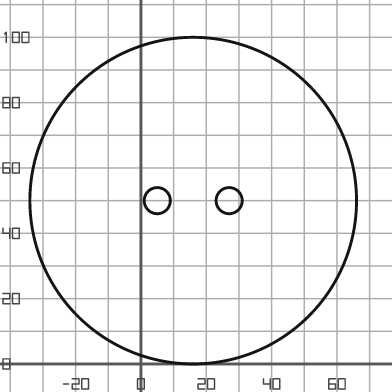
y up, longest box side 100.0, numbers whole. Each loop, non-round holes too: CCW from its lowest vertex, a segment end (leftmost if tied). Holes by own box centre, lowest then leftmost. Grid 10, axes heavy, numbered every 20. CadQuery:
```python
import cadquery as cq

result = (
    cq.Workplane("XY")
    .moveTo(16.0, 50.0)
    .circle(50.0)
    .moveTo(5.0, 50.0)
    .circle(4.0)
    .moveTo(27.0, 50.0)
    .circle(4.0)
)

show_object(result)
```